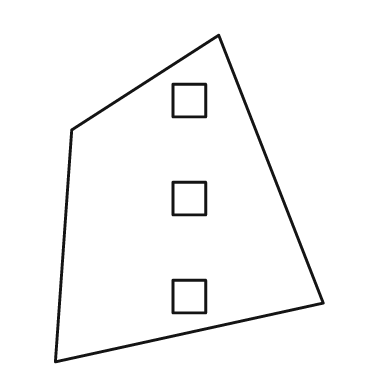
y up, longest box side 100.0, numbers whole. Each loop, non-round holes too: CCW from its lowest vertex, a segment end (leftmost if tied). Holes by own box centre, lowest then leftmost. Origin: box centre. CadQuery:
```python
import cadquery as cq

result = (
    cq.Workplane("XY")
    .moveTo(-41.0, -50.0)
    .lineTo(41.0, -32.0)
    .lineTo(9.0, 50.0)
    .lineTo(-36.0, 21.0)
    .close()
    .moveTo(-5.0, -35.0)
    .lineTo(5.0, -35.0)
    .lineTo(5.0, -25.0)
    .lineTo(-5.0, -25.0)
    .close()
    .moveTo(-5.0, -5.0)
    .lineTo(5.0, -5.0)
    .lineTo(5.0, 5.0)
    .lineTo(-5.0, 5.0)
    .close()
    .moveTo(-5.0, 25.0)
    .lineTo(5.0, 25.0)
    .lineTo(5.0, 35.0)
    .lineTo(-5.0, 35.0)
    .close()
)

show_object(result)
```